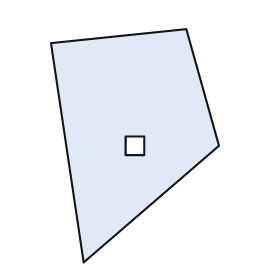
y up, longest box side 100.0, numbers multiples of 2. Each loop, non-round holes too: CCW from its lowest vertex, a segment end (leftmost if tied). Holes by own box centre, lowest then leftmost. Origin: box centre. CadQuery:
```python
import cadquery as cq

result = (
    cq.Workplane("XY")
    .moveTo(-22.0, -50.0)
    .lineTo(36.0, 0.0)
    .lineTo(22.0, 50.0)
    .lineTo(-36.0, 44.0)
    .close()
    .moveTo(-4.0, -4.0)
    .lineTo(4.0, -4.0)
    .lineTo(4.0, 4.0)
    .lineTo(-4.0, 4.0)
    .close()
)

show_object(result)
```